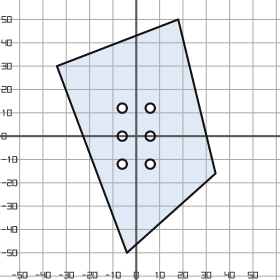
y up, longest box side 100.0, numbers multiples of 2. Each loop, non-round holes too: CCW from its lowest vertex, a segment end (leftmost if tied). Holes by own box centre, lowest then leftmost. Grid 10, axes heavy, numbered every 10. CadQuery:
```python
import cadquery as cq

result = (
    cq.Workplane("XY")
    .moveTo(-4.0, -50.0)
    .lineTo(34.0, -16.0)
    .lineTo(18.0, 50.0)
    .lineTo(-34.0, 30.0)
    .close()
    .moveTo(-6.0, -12.0)
    .circle(2.0)
    .moveTo(6.0, -12.0)
    .circle(2.0)
    .moveTo(-6.0, 0.0)
    .circle(2.0)
    .moveTo(6.0, 0.0)
    .circle(2.0)
    .moveTo(-6.0, 12.0)
    .circle(2.0)
    .moveTo(6.0, 12.0)
    .circle(2.0)
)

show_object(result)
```